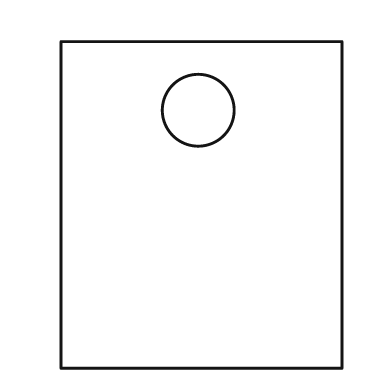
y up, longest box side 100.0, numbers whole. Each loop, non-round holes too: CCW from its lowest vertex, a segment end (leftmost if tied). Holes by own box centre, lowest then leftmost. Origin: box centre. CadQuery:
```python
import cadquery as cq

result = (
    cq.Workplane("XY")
    .moveTo(-43.0, -50.0)
    .lineTo(43.0, -50.0)
    .lineTo(43.0, 50.0)
    .lineTo(-43.0, 50.0)
    .close()
    .moveTo(-1.0, 29.0)
    .circle(11.0)
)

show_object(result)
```